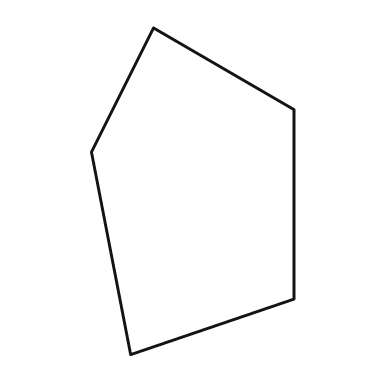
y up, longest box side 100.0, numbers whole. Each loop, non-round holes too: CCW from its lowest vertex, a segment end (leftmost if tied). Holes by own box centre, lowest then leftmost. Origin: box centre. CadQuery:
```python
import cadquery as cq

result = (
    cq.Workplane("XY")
    .moveTo(-19.0, -50.0)
    .lineTo(31.0, -33.0)
    .lineTo(31.0, 25.0)
    .lineTo(-12.0, 50.0)
    .lineTo(-31.0, 12.0)
    .close()
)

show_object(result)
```